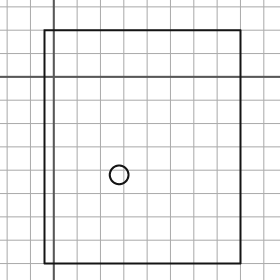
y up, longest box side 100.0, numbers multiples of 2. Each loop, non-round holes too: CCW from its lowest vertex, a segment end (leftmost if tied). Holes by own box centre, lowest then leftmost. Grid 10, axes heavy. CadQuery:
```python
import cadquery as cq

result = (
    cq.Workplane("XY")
    .moveTo(-4.0, -80.0)
    .lineTo(80.0, -80.0)
    .lineTo(80.0, 20.0)
    .lineTo(-4.0, 20.0)
    .close()
    .moveTo(28.0, -42.0)
    .circle(4.0)
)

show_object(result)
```